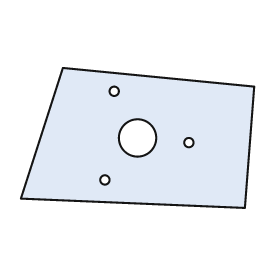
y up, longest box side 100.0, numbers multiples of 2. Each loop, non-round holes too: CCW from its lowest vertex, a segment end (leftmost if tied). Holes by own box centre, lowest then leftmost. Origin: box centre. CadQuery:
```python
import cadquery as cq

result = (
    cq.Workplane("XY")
    .moveTo(46.0, -30.0)
    .lineTo(50.0, 22.0)
    .lineTo(-32.0, 30.0)
    .lineTo(-50.0, -26.0)
    .close()
    .moveTo(-14.0, -18.0)
    .circle(2.0)
    .moveTo(22.0, -2.0)
    .circle(2.0)
    .moveTo(0.0, 0.0)
    .circle(8.0)
    .moveTo(-10.0, 20.0)
    .circle(2.0)
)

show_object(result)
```